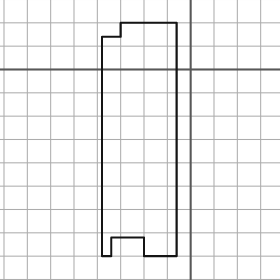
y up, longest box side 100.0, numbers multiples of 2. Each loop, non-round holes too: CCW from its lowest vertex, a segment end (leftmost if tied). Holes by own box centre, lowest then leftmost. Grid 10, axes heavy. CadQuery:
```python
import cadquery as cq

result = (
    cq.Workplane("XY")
    .moveTo(-38.0, -80.0)
    .lineTo(-34.0, -80.0)
    .lineTo(-34.0, -72.0)
    .lineTo(-20.0, -72.0)
    .lineTo(-20.0, -80.0)
    .lineTo(-6.0, -80.0)
    .lineTo(-6.0, 20.0)
    .lineTo(-30.0, 20.0)
    .lineTo(-30.0, 14.0)
    .lineTo(-38.0, 14.0)
    .close()
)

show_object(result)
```